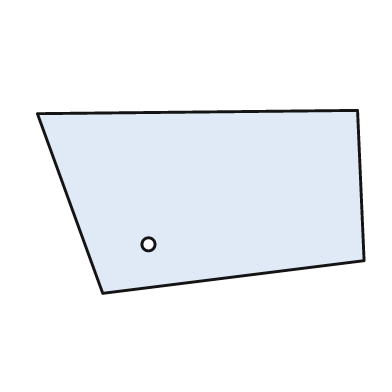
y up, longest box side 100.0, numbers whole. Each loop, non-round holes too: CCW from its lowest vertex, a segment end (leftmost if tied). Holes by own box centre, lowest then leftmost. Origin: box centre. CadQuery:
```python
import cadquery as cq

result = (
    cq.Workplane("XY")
    .moveTo(-30.0, -28.0)
    .lineTo(50.0, -18.0)
    .lineTo(48.0, 28.0)
    .lineTo(-50.0, 27.0)
    .close()
    .moveTo(-16.0, -13.0)
    .circle(2.0)
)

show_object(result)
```